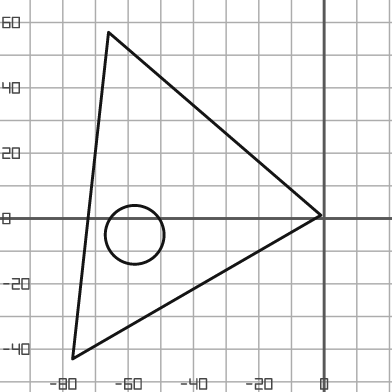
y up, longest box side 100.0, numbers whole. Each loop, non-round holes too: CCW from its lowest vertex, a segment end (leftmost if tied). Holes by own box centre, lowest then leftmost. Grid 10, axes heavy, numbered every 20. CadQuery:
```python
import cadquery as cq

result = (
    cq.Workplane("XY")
    .moveTo(-77.0, -43.0)
    .lineTo(-1.0, 1.0)
    .lineTo(-66.0, 57.0)
    .close()
    .moveTo(-58.0, -5.0)
    .circle(9.0)
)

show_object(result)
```